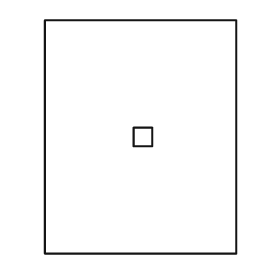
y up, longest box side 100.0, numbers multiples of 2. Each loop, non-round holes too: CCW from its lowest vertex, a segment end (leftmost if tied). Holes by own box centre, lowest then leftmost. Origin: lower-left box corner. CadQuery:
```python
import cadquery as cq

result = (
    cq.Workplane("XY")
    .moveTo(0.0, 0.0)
    .lineTo(82.0, 0.0)
    .lineTo(82.0, 100.0)
    .lineTo(0.0, 100.0)
    .close()
    .moveTo(38.0, 46.0)
    .lineTo(46.0, 46.0)
    .lineTo(46.0, 54.0)
    .lineTo(38.0, 54.0)
    .close()
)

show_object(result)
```